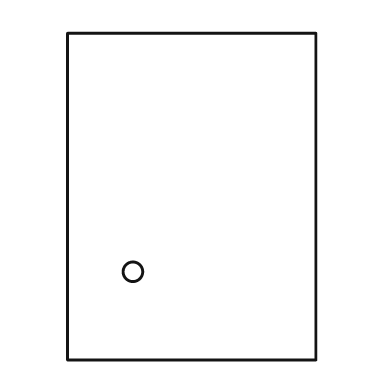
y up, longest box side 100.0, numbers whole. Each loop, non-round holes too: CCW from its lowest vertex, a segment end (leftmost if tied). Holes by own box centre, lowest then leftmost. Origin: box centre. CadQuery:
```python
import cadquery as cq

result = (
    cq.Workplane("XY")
    .moveTo(-38.0, -50.0)
    .lineTo(38.0, -50.0)
    .lineTo(38.0, 50.0)
    .lineTo(-38.0, 50.0)
    .close()
    .moveTo(-18.0, -23.0)
    .circle(3.0)
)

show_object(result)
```